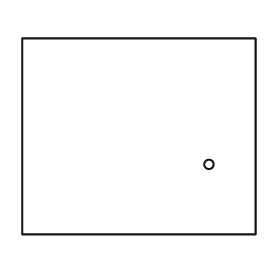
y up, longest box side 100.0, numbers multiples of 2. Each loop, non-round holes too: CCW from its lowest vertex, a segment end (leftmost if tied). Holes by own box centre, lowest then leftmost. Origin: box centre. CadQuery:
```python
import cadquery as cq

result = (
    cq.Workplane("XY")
    .moveTo(-50.0, -42.0)
    .lineTo(50.0, -42.0)
    .lineTo(50.0, 42.0)
    .lineTo(-50.0, 42.0)
    .close()
    .moveTo(30.0, -12.0)
    .circle(2.0)
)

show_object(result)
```